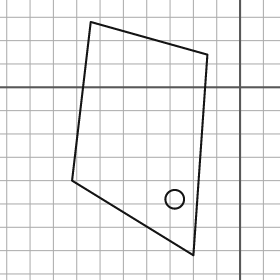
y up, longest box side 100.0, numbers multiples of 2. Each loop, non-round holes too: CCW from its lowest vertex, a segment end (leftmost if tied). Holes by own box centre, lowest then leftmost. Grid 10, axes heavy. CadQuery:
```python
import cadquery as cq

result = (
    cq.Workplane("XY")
    .moveTo(-20.0, -72.0)
    .lineTo(-14.0, 14.0)
    .lineTo(-64.0, 28.0)
    .lineTo(-72.0, -40.0)
    .close()
    .moveTo(-28.0, -48.0)
    .circle(4.0)
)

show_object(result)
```